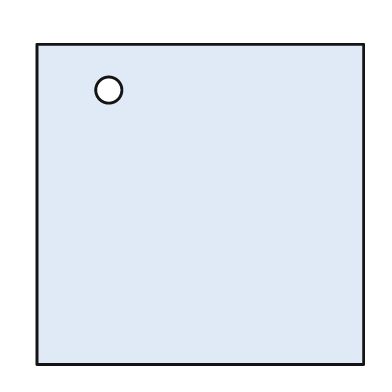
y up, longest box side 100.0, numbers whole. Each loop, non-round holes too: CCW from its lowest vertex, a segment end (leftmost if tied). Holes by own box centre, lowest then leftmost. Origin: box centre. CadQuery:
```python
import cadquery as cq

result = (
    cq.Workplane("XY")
    .moveTo(-50.0, -49.0)
    .lineTo(50.0, -49.0)
    .lineTo(50.0, 49.0)
    .lineTo(-50.0, 49.0)
    .close()
    .moveTo(-28.0, 35.0)
    .circle(4.0)
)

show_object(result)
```